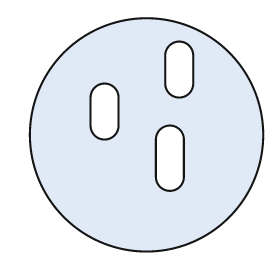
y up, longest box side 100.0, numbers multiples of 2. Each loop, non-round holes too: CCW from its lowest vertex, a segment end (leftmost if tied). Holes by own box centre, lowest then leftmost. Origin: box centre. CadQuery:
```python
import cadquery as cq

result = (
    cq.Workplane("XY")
    .moveTo(0.0, 0.0)
    .circle(50.0)
    .moveTo(4.0, -18.0)
    .threePointArc((10.0, -24.0), (16.0, -18.0))
    .lineTo(16.0, -2.0)
    .threePointArc((10.0, 4.0), (4.0, -2.0))
    .close()
    .moveTo(-24.0, 4.0)
    .threePointArc((-18.0, -2.0), (-12.0, 4.0))
    .lineTo(-12.0, 16.0)
    .threePointArc((-18.0, 22.0), (-24.0, 16.0))
    .close()
    .moveTo(8.0, 22.0)
    .threePointArc((14.0, 16.0), (20.0, 22.0))
    .lineTo(20.0, 34.0)
    .threePointArc((14.0, 40.0), (8.0, 34.0))
    .close()
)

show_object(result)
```